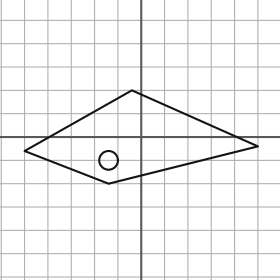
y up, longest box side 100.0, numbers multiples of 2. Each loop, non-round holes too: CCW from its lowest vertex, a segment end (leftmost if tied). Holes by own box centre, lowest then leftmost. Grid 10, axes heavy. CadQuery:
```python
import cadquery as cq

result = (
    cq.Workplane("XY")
    .moveTo(-14.0, -20.0)
    .lineTo(50.0, -4.0)
    .lineTo(-4.0, 20.0)
    .lineTo(-50.0, -6.0)
    .close()
    .moveTo(-14.0, -10.0)
    .circle(4.0)
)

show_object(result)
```